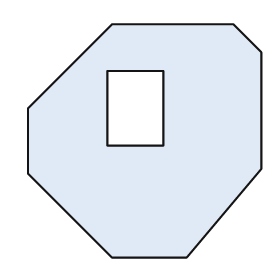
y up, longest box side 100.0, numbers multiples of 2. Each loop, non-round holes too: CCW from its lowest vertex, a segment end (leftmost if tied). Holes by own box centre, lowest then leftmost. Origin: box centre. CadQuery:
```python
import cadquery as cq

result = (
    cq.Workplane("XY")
    .moveTo(-14.0, -50.0)
    .lineTo(18.0, -50.0)
    .lineTo(50.0, -12.0)
    .lineTo(50.0, 38.0)
    .lineTo(38.0, 50.0)
    .lineTo(-14.0, 50.0)
    .lineTo(-50.0, 14.0)
    .lineTo(-50.0, -14.0)
    .close()
    .moveTo(-16.0, -2.0)
    .lineTo(8.0, -2.0)
    .lineTo(8.0, 30.0)
    .lineTo(-16.0, 30.0)
    .close()
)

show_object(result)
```